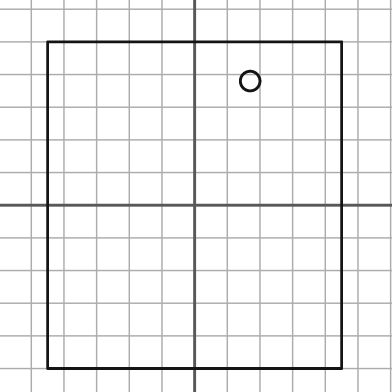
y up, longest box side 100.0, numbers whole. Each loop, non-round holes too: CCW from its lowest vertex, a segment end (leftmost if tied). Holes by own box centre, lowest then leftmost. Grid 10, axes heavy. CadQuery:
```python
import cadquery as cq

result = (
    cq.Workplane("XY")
    .moveTo(-45.0, -50.0)
    .lineTo(45.0, -50.0)
    .lineTo(45.0, 50.0)
    .lineTo(-45.0, 50.0)
    .close()
    .moveTo(17.0, 38.0)
    .circle(3.0)
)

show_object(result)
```